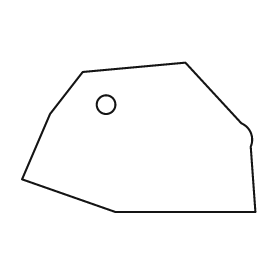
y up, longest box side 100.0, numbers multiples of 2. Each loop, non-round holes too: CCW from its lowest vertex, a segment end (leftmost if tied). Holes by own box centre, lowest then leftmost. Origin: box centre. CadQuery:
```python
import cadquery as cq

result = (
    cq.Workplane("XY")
    .moveTo(-10.0, -32.0)
    .lineTo(50.0, -32.0)
    .lineTo(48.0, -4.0)
    .threePointArc((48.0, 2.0), (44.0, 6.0))
    .lineTo(20.0, 32.0)
    .lineTo(-24.0, 28.0)
    .lineTo(-38.0, 10.0)
    .lineTo(-50.0, -18.0)
    .close()
    .moveTo(-14.0, 14.0)
    .circle(4.0)
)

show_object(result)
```